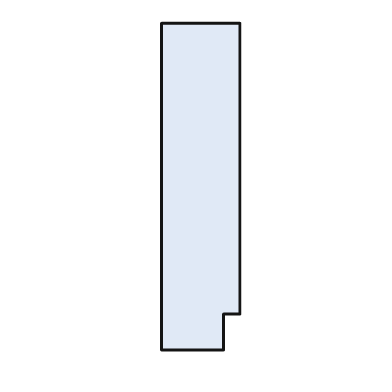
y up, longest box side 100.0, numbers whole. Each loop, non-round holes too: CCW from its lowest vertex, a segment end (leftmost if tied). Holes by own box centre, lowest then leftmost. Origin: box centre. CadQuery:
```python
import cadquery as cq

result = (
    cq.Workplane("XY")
    .moveTo(-12.0, -50.0)
    .lineTo(7.0, -50.0)
    .lineTo(7.0, -39.0)
    .lineTo(12.0, -39.0)
    .lineTo(12.0, 50.0)
    .lineTo(-12.0, 50.0)
    .close()
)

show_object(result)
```